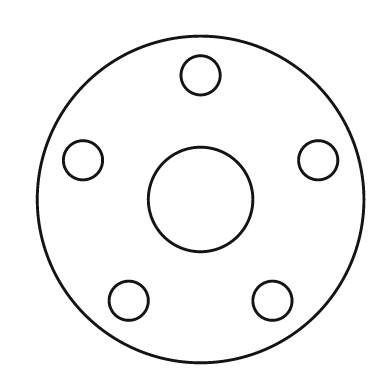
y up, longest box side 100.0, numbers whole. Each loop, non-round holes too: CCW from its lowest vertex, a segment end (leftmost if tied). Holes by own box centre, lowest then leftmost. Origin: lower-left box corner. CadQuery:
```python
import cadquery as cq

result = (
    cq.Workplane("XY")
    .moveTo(50.0, 50.0)
    .circle(50.0)
    .moveTo(28.0, 19.0)
    .circle(6.0)
    .moveTo(72.0, 19.0)
    .circle(6.0)
    .moveTo(50.0, 50.0)
    .circle(16.0)
    .moveTo(14.0, 62.0)
    .circle(6.0)
    .moveTo(86.0, 62.0)
    .circle(6.0)
    .moveTo(50.0, 88.0)
    .circle(6.0)
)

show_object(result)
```